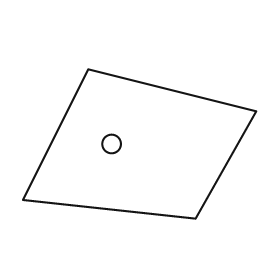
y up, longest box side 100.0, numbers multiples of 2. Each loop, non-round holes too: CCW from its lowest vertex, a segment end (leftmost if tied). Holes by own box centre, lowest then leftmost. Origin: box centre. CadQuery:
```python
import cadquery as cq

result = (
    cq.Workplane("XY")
    .moveTo(24.0, -32.0)
    .lineTo(50.0, 14.0)
    .lineTo(-22.0, 32.0)
    .lineTo(-50.0, -24.0)
    .close()
    .moveTo(-12.0, 0.0)
    .circle(4.0)
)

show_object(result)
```